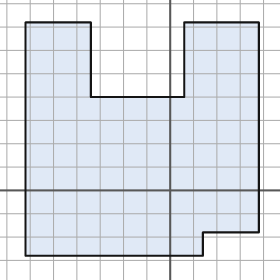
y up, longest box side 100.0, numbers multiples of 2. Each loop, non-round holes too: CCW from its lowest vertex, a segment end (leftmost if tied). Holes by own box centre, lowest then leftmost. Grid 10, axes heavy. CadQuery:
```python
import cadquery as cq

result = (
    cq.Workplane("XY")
    .moveTo(-62.0, -28.0)
    .lineTo(14.0, -28.0)
    .lineTo(14.0, -18.0)
    .lineTo(38.0, -18.0)
    .lineTo(38.0, 72.0)
    .lineTo(6.0, 72.0)
    .lineTo(6.0, 40.0)
    .lineTo(-34.0, 40.0)
    .lineTo(-34.0, 72.0)
    .lineTo(-62.0, 72.0)
    .close()
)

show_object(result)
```